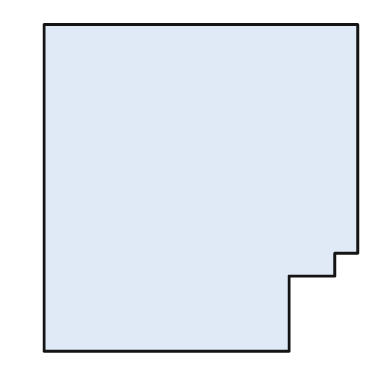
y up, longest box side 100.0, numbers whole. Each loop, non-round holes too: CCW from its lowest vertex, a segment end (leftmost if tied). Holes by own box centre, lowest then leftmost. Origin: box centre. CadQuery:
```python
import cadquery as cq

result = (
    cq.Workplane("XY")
    .moveTo(-48.0, -50.0)
    .lineTo(27.0, -50.0)
    .lineTo(27.0, -27.0)
    .lineTo(41.0, -27.0)
    .lineTo(41.0, -20.0)
    .lineTo(48.0, -20.0)
    .lineTo(48.0, 50.0)
    .lineTo(-48.0, 50.0)
    .close()
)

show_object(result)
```